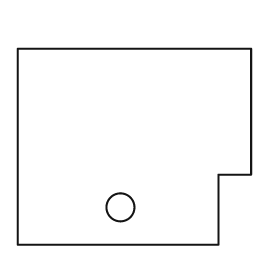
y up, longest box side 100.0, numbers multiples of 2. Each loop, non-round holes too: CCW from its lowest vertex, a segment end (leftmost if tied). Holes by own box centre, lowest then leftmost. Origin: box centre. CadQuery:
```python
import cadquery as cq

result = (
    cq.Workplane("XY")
    .moveTo(-50.0, -42.0)
    .lineTo(36.0, -42.0)
    .lineTo(36.0, -12.0)
    .lineTo(50.0, -12.0)
    .lineTo(50.0, 42.0)
    .lineTo(-50.0, 42.0)
    .close()
    .moveTo(-6.0, -26.0)
    .circle(6.0)
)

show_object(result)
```